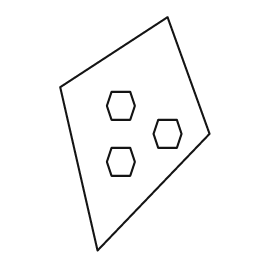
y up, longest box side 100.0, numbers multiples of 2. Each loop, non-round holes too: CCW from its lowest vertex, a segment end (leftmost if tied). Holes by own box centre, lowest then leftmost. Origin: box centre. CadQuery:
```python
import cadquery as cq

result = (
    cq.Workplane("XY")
    .moveTo(-16.0, -50.0)
    .lineTo(32.0, 0.0)
    .lineTo(14.0, 50.0)
    .lineTo(-32.0, 20.0)
    .close()
    .moveTo(-10.0, -18.0)
    .lineTo(-2.0, -18.0)
    .lineTo(0.0, -12.0)
    .lineTo(-2.0, -6.0)
    .lineTo(-10.0, -6.0)
    .lineTo(-12.0, -12.0)
    .close()
    .moveTo(10.0, -6.0)
    .lineTo(18.0, -6.0)
    .lineTo(20.0, 0.0)
    .lineTo(18.0, 6.0)
    .lineTo(10.0, 6.0)
    .lineTo(8.0, 0.0)
    .close()
    .moveTo(-10.0, 6.0)
    .lineTo(-2.0, 6.0)
    .lineTo(0.0, 12.0)
    .lineTo(-2.0, 18.0)
    .lineTo(-10.0, 18.0)
    .lineTo(-12.0, 12.0)
    .close()
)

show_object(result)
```